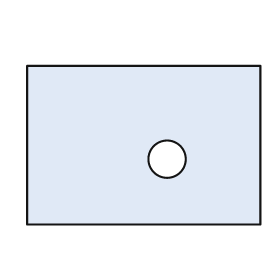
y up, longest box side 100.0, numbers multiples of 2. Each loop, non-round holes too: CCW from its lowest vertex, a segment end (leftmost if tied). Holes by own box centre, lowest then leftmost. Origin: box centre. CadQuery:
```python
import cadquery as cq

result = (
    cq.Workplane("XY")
    .moveTo(-50.0, -34.0)
    .lineTo(50.0, -34.0)
    .lineTo(50.0, 34.0)
    .lineTo(-50.0, 34.0)
    .close()
    .moveTo(10.0, -6.0)
    .circle(8.0)
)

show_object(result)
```